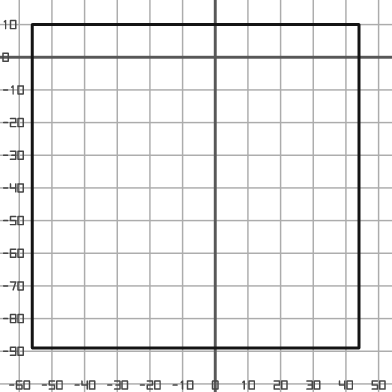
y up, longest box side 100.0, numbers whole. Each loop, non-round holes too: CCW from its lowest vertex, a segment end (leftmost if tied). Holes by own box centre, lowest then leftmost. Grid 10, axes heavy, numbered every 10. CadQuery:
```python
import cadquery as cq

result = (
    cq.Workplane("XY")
    .moveTo(-56.0, -89.0)
    .lineTo(44.0, -89.0)
    .lineTo(44.0, 10.0)
    .lineTo(-56.0, 10.0)
    .close()
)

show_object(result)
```